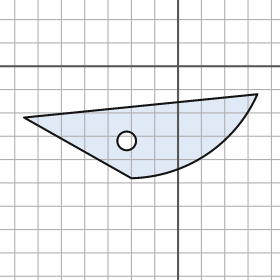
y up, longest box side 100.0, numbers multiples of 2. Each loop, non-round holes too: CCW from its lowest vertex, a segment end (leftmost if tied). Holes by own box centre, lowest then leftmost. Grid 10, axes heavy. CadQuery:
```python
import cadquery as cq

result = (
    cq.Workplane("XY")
    .moveTo(-20.0, -48.0)
    .threePointArc((12.0, -38.0), (34.0, -12.0))
    .lineTo(-66.0, -22.0)
    .close()
    .moveTo(-22.0, -32.0)
    .circle(4.0)
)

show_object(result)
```